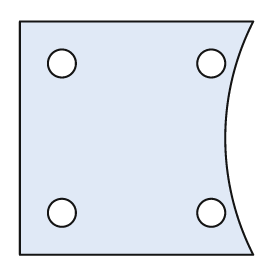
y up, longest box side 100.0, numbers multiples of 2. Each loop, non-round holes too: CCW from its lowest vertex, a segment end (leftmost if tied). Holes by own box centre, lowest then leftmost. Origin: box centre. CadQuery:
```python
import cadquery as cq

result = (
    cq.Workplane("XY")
    .moveTo(-50.0, -50.0)
    .lineTo(50.0, -50.0)
    .threePointArc((38.0, 0.0), (50.0, 50.0))
    .lineTo(-50.0, 50.0)
    .close()
    .moveTo(-32.0, -32.0)
    .circle(6.0)
    .moveTo(32.0, -32.0)
    .circle(6.0)
    .moveTo(-32.0, 32.0)
    .circle(6.0)
    .moveTo(32.0, 32.0)
    .circle(6.0)
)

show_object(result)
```